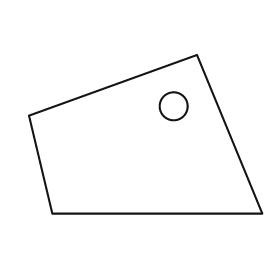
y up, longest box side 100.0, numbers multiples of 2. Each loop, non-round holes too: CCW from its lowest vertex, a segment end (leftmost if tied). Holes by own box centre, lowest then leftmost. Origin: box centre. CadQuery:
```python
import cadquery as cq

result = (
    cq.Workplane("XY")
    .moveTo(-40.0, -34.0)
    .lineTo(50.0, -34.0)
    .lineTo(22.0, 34.0)
    .lineTo(-50.0, 8.0)
    .close()
    .moveTo(12.0, 12.0)
    .circle(6.0)
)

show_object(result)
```